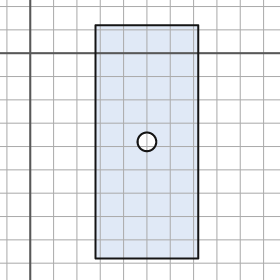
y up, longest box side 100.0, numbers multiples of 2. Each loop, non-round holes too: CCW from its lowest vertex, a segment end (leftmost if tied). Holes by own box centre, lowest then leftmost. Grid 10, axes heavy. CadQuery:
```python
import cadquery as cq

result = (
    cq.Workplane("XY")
    .moveTo(28.0, -88.0)
    .lineTo(72.0, -88.0)
    .lineTo(72.0, 12.0)
    .lineTo(28.0, 12.0)
    .close()
    .moveTo(50.0, -38.0)
    .circle(4.0)
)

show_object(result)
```